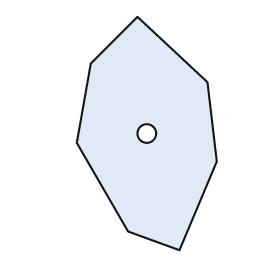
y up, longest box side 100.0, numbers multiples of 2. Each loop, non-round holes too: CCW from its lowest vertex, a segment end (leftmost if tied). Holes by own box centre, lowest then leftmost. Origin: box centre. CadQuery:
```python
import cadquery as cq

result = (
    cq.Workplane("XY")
    .moveTo(14.0, -50.0)
    .lineTo(30.0, -12.0)
    .lineTo(26.0, 22.0)
    .lineTo(-4.0, 50.0)
    .lineTo(-24.0, 30.0)
    .lineTo(-30.0, -4.0)
    .lineTo(-8.0, -42.0)
    .close()
    .moveTo(0.0, 0.0)
    .circle(4.0)
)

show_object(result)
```